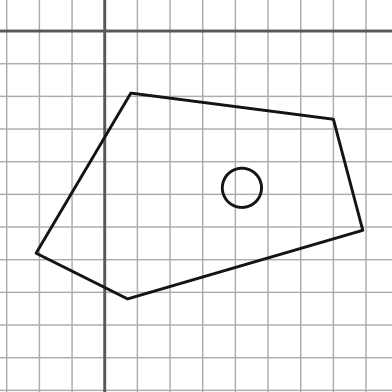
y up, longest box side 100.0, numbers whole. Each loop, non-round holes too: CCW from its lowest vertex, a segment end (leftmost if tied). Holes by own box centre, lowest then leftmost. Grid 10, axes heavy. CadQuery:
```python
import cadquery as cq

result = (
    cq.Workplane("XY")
    .moveTo(7.0, -82.0)
    .lineTo(79.0, -61.0)
    .lineTo(70.0, -27.0)
    .lineTo(8.0, -19.0)
    .lineTo(-21.0, -68.0)
    .close()
    .moveTo(42.0, -48.0)
    .circle(6.0)
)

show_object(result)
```